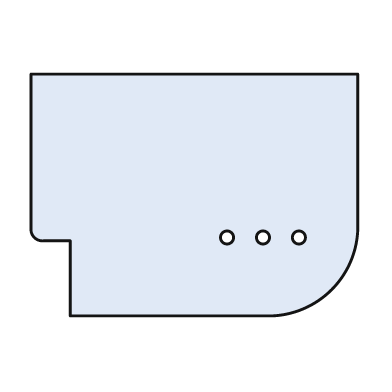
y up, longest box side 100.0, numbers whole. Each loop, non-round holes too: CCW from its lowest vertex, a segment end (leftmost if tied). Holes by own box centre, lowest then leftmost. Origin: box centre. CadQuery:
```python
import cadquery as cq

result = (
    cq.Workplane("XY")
    .moveTo(-38.0, -37.0)
    .lineTo(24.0, -37.0)
    .threePointArc((42.0, -29.0), (50.0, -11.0))
    .lineTo(50.0, 37.0)
    .lineTo(-50.0, 37.0)
    .lineTo(-50.0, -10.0)
    .threePointArc((-49.0, -13.0), (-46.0, -14.0))
    .lineTo(-38.0, -14.0)
    .close()
    .moveTo(10.0, -13.0)
    .circle(2.0)
    .moveTo(21.0, -13.0)
    .circle(2.0)
    .moveTo(32.0, -13.0)
    .circle(2.0)
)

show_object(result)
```